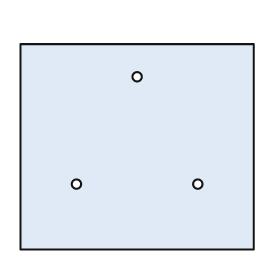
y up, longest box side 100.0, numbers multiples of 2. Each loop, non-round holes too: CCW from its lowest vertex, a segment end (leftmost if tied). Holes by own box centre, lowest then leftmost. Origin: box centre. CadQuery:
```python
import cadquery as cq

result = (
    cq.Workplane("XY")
    .moveTo(-50.0, -44.0)
    .lineTo(50.0, -44.0)
    .lineTo(50.0, 44.0)
    .lineTo(-50.0, 44.0)
    .close()
    .moveTo(-26.0, -16.0)
    .circle(2.0)
    .moveTo(26.0, -16.0)
    .circle(2.0)
    .moveTo(0.0, 30.0)
    .circle(2.0)
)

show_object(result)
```